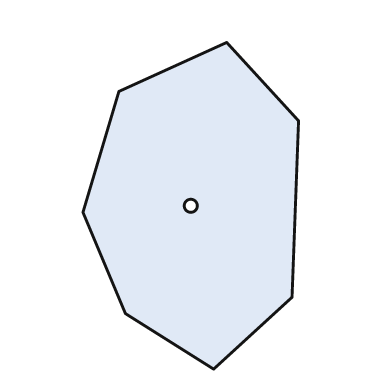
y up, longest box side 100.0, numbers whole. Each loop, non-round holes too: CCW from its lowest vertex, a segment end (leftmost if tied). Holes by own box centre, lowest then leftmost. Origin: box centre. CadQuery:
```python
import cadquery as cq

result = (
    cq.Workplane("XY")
    .moveTo(7.0, -50.0)
    .lineTo(31.0, -28.0)
    .lineTo(33.0, 26.0)
    .lineTo(11.0, 50.0)
    .lineTo(-22.0, 35.0)
    .lineTo(-33.0, -2.0)
    .lineTo(-20.0, -33.0)
    .close()
    .moveTo(0.0, 0.0)
    .circle(2.0)
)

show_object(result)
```